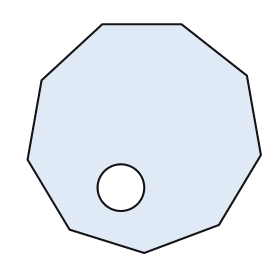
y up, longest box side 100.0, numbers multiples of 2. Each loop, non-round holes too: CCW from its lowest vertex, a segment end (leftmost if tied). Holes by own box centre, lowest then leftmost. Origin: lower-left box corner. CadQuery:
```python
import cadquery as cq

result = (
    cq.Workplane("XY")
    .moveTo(50.0, 0.0)
    .lineTo(82.0, 12.0)
    .lineTo(100.0, 42.0)
    .lineTo(94.0, 76.0)
    .lineTo(66.0, 98.0)
    .lineTo(32.0, 98.0)
    .lineTo(6.0, 74.0)
    .lineTo(0.0, 40.0)
    .lineTo(18.0, 10.0)
    .close()
    .moveTo(40.0, 28.0)
    .circle(10.0)
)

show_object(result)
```